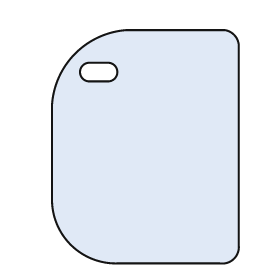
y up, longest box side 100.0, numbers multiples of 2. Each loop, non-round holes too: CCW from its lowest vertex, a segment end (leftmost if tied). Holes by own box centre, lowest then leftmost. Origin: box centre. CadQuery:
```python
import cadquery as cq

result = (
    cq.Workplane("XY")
    .moveTo(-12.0, -50.0)
    .lineTo(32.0, -50.0)
    .threePointArc((38.0, -48.0), (40.0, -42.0))
    .lineTo(40.0, 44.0)
    .threePointArc((38.0, 48.0), (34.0, 50.0))
    .lineTo(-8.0, 50.0)
    .threePointArc((-30.0, 40.0), (-40.0, 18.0))
    .lineTo(-40.0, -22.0)
    .threePointArc((-32.0, -42.0), (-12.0, -50.0))
    .close()
    .moveTo(-24.0, 28.0)
    .lineTo(-16.0, 28.0)
    .threePointArc((-12.0, 32.0), (-16.0, 36.0))
    .lineTo(-24.0, 36.0)
    .threePointArc((-28.0, 32.0), (-24.0, 28.0))
    .close()
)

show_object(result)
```